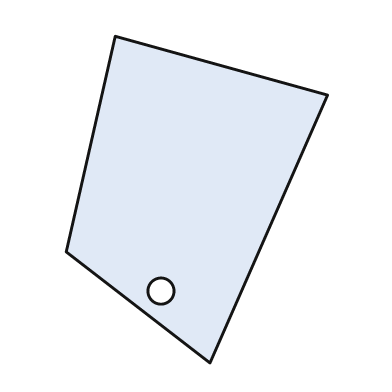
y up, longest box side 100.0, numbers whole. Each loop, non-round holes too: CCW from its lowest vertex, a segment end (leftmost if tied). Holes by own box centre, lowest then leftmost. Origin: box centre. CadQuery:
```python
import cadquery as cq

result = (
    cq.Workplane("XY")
    .moveTo(4.0, -50.0)
    .lineTo(40.0, 32.0)
    .lineTo(-25.0, 50.0)
    .lineTo(-40.0, -16.0)
    .close()
    .moveTo(-11.0, -28.0)
    .circle(4.0)
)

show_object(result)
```